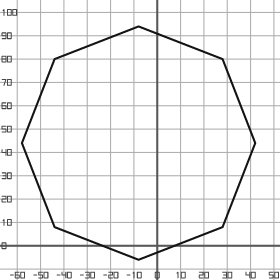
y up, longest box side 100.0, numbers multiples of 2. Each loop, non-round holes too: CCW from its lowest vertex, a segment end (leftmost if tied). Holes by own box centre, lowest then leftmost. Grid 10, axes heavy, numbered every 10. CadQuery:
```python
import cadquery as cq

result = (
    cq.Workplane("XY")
    .moveTo(-8.0, -6.0)
    .lineTo(28.0, 8.0)
    .lineTo(42.0, 44.0)
    .lineTo(28.0, 80.0)
    .lineTo(-8.0, 94.0)
    .lineTo(-44.0, 80.0)
    .lineTo(-58.0, 44.0)
    .lineTo(-44.0, 8.0)
    .close()
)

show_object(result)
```